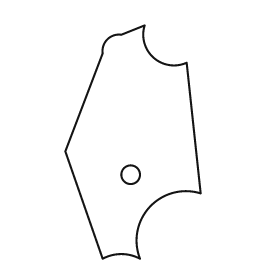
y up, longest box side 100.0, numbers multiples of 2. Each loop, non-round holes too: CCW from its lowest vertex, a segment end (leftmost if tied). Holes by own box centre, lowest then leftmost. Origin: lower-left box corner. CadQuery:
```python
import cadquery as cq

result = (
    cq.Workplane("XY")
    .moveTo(16.0, 0.0)
    .threePointArc((24.0, 2.0), (32.0, 0.0))
    .threePointArc((36.0, 22.0), (58.0, 28.0))
    .lineTo(52.0, 84.0)
    .threePointArc((38.0, 86.0), (34.0, 100.0))
    .lineTo(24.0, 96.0)
    .threePointArc((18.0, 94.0), (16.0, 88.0))
    .lineTo(0.0, 46.0)
    .close()
    .moveTo(28.0, 36.0)
    .circle(4.0)
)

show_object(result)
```